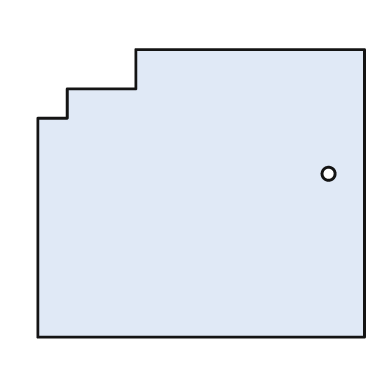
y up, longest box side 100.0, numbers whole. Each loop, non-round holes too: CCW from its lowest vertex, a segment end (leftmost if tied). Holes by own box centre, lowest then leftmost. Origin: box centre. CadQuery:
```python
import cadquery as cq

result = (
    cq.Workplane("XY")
    .moveTo(-50.0, -44.0)
    .lineTo(50.0, -44.0)
    .lineTo(50.0, 44.0)
    .lineTo(-20.0, 44.0)
    .lineTo(-20.0, 32.0)
    .lineTo(-41.0, 32.0)
    .lineTo(-41.0, 23.0)
    .lineTo(-50.0, 23.0)
    .close()
    .moveTo(39.0, 6.0)
    .circle(2.0)
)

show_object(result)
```